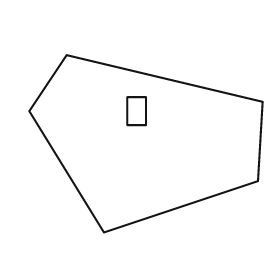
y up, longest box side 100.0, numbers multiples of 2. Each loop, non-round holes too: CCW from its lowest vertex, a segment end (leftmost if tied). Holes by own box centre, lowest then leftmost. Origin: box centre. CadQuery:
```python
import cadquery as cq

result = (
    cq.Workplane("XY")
    .moveTo(-18.0, -38.0)
    .lineTo(48.0, -16.0)
    .lineTo(50.0, 18.0)
    .lineTo(-34.0, 38.0)
    .lineTo(-50.0, 14.0)
    .close()
    .moveTo(-8.0, 8.0)
    .lineTo(0.0, 8.0)
    .lineTo(0.0, 20.0)
    .lineTo(-8.0, 20.0)
    .close()
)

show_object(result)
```